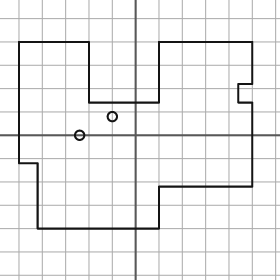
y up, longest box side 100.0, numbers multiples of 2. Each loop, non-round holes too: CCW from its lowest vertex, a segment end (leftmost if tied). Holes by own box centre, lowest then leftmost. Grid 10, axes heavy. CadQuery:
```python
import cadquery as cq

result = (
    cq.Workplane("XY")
    .moveTo(-42.0, -40.0)
    .lineTo(10.0, -40.0)
    .lineTo(10.0, -22.0)
    .lineTo(50.0, -22.0)
    .lineTo(50.0, 14.0)
    .lineTo(44.0, 14.0)
    .lineTo(44.0, 22.0)
    .lineTo(50.0, 22.0)
    .lineTo(50.0, 40.0)
    .lineTo(10.0, 40.0)
    .lineTo(10.0, 14.0)
    .lineTo(-20.0, 14.0)
    .lineTo(-20.0, 40.0)
    .lineTo(-50.0, 40.0)
    .lineTo(-50.0, -12.0)
    .lineTo(-42.0, -12.0)
    .close()
    .moveTo(-24.0, 0.0)
    .circle(2.0)
    .moveTo(-10.0, 8.0)
    .circle(2.0)
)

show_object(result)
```